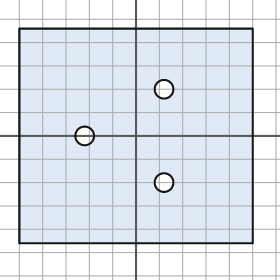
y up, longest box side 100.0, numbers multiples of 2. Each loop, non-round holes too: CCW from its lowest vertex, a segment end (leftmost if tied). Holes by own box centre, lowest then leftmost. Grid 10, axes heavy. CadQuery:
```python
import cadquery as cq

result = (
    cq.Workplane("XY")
    .moveTo(-50.0, -46.0)
    .lineTo(50.0, -46.0)
    .lineTo(50.0, 46.0)
    .lineTo(-50.0, 46.0)
    .close()
    .moveTo(12.0, -20.0)
    .circle(4.0)
    .moveTo(-22.0, 0.0)
    .circle(4.0)
    .moveTo(12.0, 20.0)
    .circle(4.0)
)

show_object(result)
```